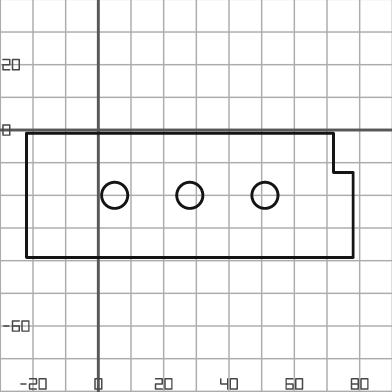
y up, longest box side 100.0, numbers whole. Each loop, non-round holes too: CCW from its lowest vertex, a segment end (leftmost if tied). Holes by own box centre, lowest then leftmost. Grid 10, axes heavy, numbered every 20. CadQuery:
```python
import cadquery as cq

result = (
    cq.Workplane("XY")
    .moveTo(-22.0, -39.0)
    .lineTo(78.0, -39.0)
    .lineTo(78.0, -13.0)
    .lineTo(72.0, -13.0)
    .lineTo(72.0, -1.0)
    .lineTo(-22.0, -1.0)
    .close()
    .moveTo(5.0, -20.0)
    .circle(4.0)
    .moveTo(28.0, -20.0)
    .circle(4.0)
    .moveTo(51.0, -20.0)
    .circle(4.0)
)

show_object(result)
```